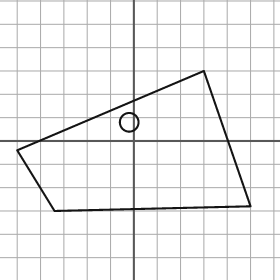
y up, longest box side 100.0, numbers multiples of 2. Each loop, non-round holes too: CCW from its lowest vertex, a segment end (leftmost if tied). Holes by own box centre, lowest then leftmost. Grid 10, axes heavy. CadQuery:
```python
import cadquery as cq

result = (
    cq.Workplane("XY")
    .moveTo(-34.0, -30.0)
    .lineTo(50.0, -28.0)
    .lineTo(30.0, 30.0)
    .lineTo(-50.0, -4.0)
    .close()
    .moveTo(-2.0, 8.0)
    .circle(4.0)
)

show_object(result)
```